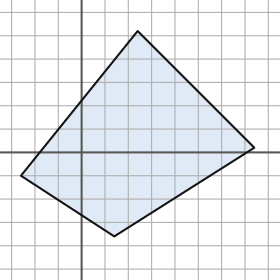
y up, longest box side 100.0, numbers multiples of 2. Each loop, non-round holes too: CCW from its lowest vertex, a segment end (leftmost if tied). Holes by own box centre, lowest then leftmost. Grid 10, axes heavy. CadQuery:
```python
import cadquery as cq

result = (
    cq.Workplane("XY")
    .moveTo(14.0, -36.0)
    .lineTo(74.0, 2.0)
    .lineTo(24.0, 52.0)
    .lineTo(-26.0, -10.0)
    .close()
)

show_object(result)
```